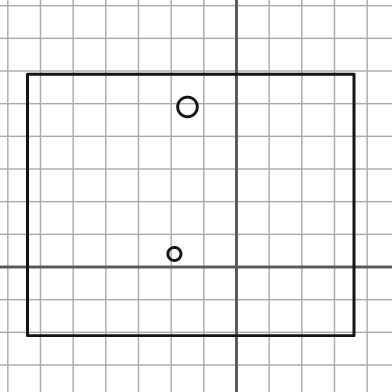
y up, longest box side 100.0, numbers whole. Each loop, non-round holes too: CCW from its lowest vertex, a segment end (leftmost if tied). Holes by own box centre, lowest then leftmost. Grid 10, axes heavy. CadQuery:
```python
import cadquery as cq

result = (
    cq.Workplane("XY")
    .moveTo(-64.0, -21.0)
    .lineTo(36.0, -21.0)
    .lineTo(36.0, 59.0)
    .lineTo(-64.0, 59.0)
    .close()
    .moveTo(-19.0, 4.0)
    .circle(2.0)
    .moveTo(-15.0, 49.0)
    .circle(3.0)
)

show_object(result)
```